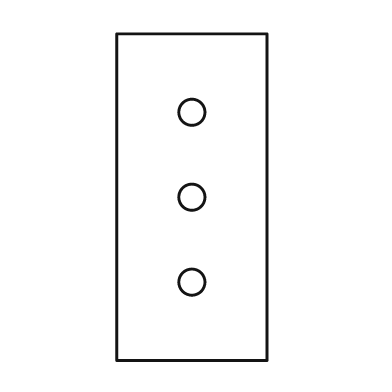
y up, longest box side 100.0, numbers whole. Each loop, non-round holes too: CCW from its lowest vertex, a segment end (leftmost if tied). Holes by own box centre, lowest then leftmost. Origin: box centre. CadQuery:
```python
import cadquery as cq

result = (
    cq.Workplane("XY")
    .moveTo(-23.0, -50.0)
    .lineTo(23.0, -50.0)
    .lineTo(23.0, 50.0)
    .lineTo(-23.0, 50.0)
    .close()
    .moveTo(0.0, -26.0)
    .circle(4.0)
    .moveTo(0.0, 0.0)
    .circle(4.0)
    .moveTo(0.0, 26.0)
    .circle(4.0)
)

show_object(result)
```